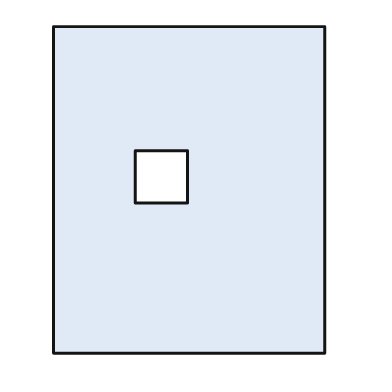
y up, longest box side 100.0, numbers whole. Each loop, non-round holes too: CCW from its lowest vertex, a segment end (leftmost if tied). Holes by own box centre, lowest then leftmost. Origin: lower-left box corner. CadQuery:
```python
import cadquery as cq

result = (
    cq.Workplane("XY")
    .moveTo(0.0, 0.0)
    .lineTo(83.0, 0.0)
    .lineTo(83.0, 100.0)
    .lineTo(0.0, 100.0)
    .close()
    .moveTo(25.0, 46.0)
    .lineTo(41.0, 46.0)
    .lineTo(41.0, 62.0)
    .lineTo(25.0, 62.0)
    .close()
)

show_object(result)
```